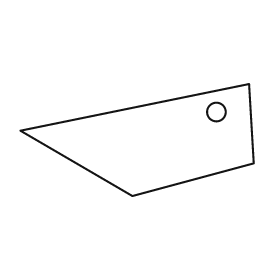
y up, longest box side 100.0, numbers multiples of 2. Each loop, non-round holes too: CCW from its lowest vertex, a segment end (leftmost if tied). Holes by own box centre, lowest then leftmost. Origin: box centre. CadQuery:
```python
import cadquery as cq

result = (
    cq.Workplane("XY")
    .moveTo(-2.0, -24.0)
    .lineTo(50.0, -10.0)
    .lineTo(48.0, 24.0)
    .lineTo(-50.0, 4.0)
    .close()
    .moveTo(34.0, 12.0)
    .circle(4.0)
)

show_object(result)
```